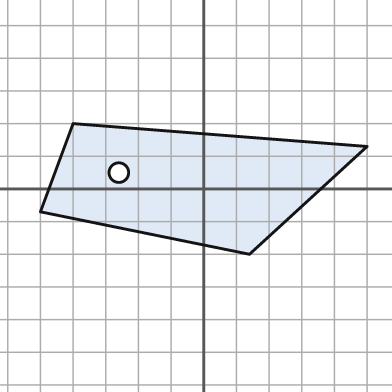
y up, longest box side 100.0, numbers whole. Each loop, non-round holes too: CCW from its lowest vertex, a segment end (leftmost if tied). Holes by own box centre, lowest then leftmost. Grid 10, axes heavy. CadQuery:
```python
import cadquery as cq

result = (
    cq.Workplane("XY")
    .moveTo(14.0, -20.0)
    .lineTo(50.0, 13.0)
    .lineTo(-40.0, 20.0)
    .lineTo(-50.0, -7.0)
    .close()
    .moveTo(-26.0, 5.0)
    .circle(3.0)
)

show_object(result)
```